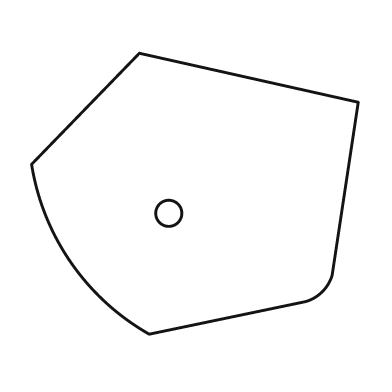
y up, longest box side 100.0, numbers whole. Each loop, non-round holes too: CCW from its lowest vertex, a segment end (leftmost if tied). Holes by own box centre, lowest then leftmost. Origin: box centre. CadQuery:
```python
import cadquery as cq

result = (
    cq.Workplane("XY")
    .moveTo(-14.0, -43.0)
    .lineTo(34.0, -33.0)
    .threePointArc((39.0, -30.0), (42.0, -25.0))
    .lineTo(50.0, 28.0)
    .lineTo(-17.0, 43.0)
    .lineTo(-50.0, 9.0)
    .threePointArc((-38.0, -21.0), (-14.0, -43.0))
    .close()
    .moveTo(-8.0, -6.0)
    .circle(4.0)
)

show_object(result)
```